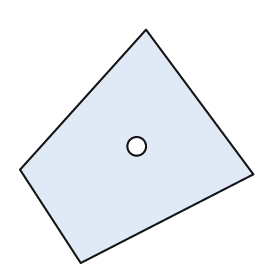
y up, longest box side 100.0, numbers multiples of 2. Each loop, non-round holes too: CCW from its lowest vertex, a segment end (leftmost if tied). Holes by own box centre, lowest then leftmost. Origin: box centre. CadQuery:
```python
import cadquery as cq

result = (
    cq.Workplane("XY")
    .moveTo(-24.0, -50.0)
    .lineTo(50.0, -12.0)
    .lineTo(4.0, 50.0)
    .lineTo(-50.0, -10.0)
    .close()
    .moveTo(0.0, 0.0)
    .circle(4.0)
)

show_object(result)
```